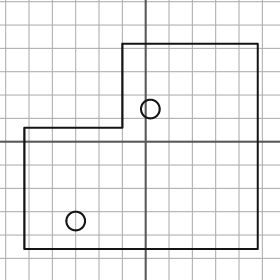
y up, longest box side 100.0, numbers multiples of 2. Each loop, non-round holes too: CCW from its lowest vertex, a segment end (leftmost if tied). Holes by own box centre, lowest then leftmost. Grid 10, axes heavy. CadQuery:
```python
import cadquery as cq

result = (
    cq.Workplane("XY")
    .moveTo(-52.0, -46.0)
    .lineTo(48.0, -46.0)
    .lineTo(48.0, 42.0)
    .lineTo(-10.0, 42.0)
    .lineTo(-10.0, 6.0)
    .lineTo(-52.0, 6.0)
    .close()
    .moveTo(-30.0, -34.0)
    .circle(4.0)
    .moveTo(2.0, 14.0)
    .circle(4.0)
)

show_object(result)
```